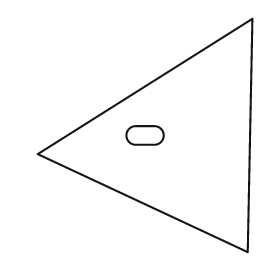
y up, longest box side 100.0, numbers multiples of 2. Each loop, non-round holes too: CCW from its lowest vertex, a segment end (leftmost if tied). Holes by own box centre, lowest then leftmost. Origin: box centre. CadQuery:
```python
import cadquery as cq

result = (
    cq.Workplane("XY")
    .moveTo(44.0, -50.0)
    .lineTo(46.0, 50.0)
    .lineTo(-46.0, -8.0)
    .close()
    .moveTo(-4.0, -4.0)
    .lineTo(4.0, -4.0)
    .threePointArc((8.0, 0.0), (4.0, 4.0))
    .lineTo(-4.0, 4.0)
    .threePointArc((-8.0, 0.0), (-4.0, -4.0))
    .close()
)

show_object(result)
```